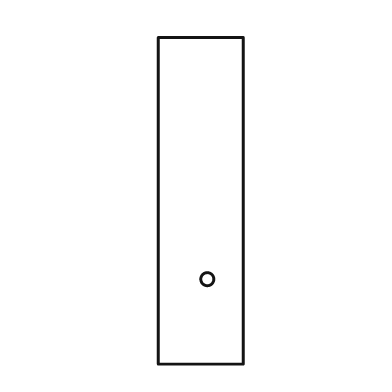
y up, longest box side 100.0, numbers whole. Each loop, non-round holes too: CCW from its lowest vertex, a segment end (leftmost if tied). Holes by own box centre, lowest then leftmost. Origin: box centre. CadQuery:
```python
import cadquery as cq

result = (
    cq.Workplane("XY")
    .moveTo(-13.0, -50.0)
    .lineTo(13.0, -50.0)
    .lineTo(13.0, 50.0)
    .lineTo(-13.0, 50.0)
    .close()
    .moveTo(2.0, -24.0)
    .circle(2.0)
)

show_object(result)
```